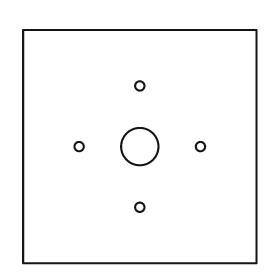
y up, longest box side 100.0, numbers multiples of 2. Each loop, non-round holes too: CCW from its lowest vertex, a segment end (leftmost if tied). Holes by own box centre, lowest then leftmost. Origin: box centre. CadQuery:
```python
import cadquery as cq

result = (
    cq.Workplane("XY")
    .moveTo(-50.0, -50.0)
    .lineTo(50.0, -50.0)
    .lineTo(50.0, 50.0)
    .lineTo(-50.0, 50.0)
    .close()
    .moveTo(0.0, -26.0)
    .circle(2.0)
    .moveTo(-26.0, 0.0)
    .circle(2.0)
    .moveTo(0.0, 0.0)
    .circle(8.0)
    .moveTo(26.0, 0.0)
    .circle(2.0)
    .moveTo(0.0, 26.0)
    .circle(2.0)
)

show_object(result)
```